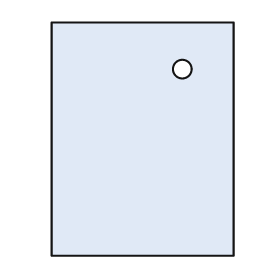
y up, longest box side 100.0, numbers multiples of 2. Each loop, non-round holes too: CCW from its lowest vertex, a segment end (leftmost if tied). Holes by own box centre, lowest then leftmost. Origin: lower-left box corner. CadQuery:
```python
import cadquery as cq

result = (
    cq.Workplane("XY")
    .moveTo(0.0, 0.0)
    .lineTo(78.0, 0.0)
    .lineTo(78.0, 100.0)
    .lineTo(0.0, 100.0)
    .close()
    .moveTo(56.0, 80.0)
    .circle(4.0)
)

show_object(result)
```